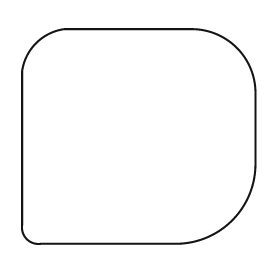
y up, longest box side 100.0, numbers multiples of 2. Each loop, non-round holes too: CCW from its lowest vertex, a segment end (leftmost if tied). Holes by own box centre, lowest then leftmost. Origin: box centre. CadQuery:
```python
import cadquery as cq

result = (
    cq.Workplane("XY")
    .moveTo(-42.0, -46.0)
    .lineTo(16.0, -46.0)
    .threePointArc((40.0, -36.0), (50.0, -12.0))
    .lineTo(50.0, 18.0)
    .threePointArc((42.0, 38.0), (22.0, 46.0))
    .lineTo(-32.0, 46.0)
    .threePointArc((-44.0, 40.0), (-50.0, 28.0))
    .lineTo(-50.0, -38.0)
    .threePointArc((-48.0, -44.0), (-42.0, -46.0))
    .close()
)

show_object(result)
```